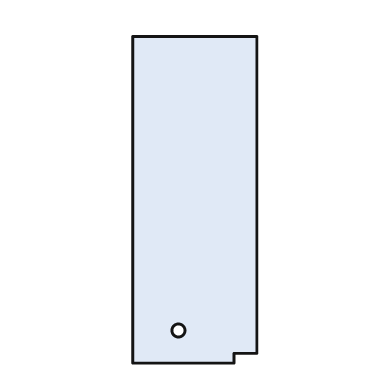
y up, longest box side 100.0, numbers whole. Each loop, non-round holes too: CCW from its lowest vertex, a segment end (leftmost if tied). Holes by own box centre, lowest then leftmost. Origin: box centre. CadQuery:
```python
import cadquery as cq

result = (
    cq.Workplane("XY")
    .moveTo(-19.0, -50.0)
    .lineTo(12.0, -50.0)
    .lineTo(12.0, -47.0)
    .lineTo(19.0, -47.0)
    .lineTo(19.0, 50.0)
    .lineTo(-19.0, 50.0)
    .close()
    .moveTo(-5.0, -40.0)
    .circle(2.0)
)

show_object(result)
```